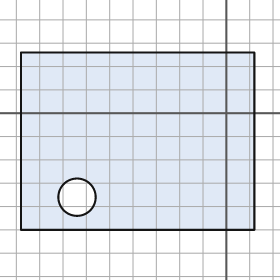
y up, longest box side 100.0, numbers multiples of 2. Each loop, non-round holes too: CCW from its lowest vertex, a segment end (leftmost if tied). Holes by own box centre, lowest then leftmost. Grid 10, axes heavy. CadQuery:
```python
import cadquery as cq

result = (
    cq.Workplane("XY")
    .moveTo(-88.0, -50.0)
    .lineTo(12.0, -50.0)
    .lineTo(12.0, 26.0)
    .lineTo(-88.0, 26.0)
    .close()
    .moveTo(-64.0, -36.0)
    .circle(8.0)
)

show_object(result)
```